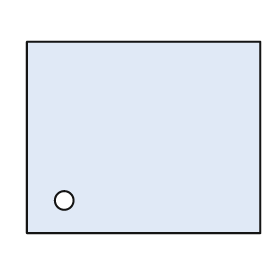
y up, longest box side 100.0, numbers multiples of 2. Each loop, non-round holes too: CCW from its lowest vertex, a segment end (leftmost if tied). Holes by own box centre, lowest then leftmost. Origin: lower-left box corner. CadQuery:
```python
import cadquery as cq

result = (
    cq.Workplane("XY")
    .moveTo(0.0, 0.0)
    .lineTo(100.0, 0.0)
    .lineTo(100.0, 82.0)
    .lineTo(0.0, 82.0)
    .close()
    .moveTo(16.0, 14.0)
    .circle(4.0)
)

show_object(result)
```